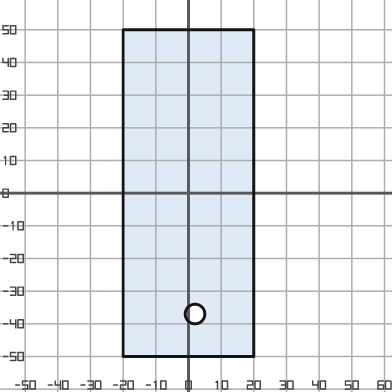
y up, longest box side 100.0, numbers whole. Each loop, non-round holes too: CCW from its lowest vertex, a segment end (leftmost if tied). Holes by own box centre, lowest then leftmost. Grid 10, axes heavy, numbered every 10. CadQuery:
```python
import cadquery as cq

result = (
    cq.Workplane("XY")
    .moveTo(-20.0, -50.0)
    .lineTo(20.0, -50.0)
    .lineTo(20.0, 50.0)
    .lineTo(-20.0, 50.0)
    .close()
    .moveTo(2.0, -37.0)
    .circle(3.0)
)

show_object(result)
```